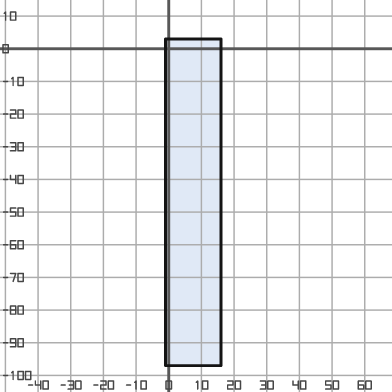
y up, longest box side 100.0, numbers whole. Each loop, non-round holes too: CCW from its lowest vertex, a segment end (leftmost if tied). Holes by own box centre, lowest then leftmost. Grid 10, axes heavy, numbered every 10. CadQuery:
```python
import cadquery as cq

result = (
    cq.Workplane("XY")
    .moveTo(-1.0, -97.0)
    .lineTo(16.0, -97.0)
    .lineTo(16.0, 3.0)
    .lineTo(-1.0, 3.0)
    .close()
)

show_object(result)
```